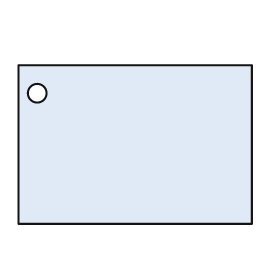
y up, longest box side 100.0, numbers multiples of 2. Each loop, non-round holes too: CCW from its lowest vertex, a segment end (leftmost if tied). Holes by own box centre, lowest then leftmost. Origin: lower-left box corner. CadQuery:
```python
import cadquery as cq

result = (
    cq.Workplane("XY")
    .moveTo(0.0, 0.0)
    .lineTo(100.0, 0.0)
    .lineTo(100.0, 68.0)
    .lineTo(0.0, 68.0)
    .close()
    .moveTo(8.0, 56.0)
    .circle(4.0)
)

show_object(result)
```